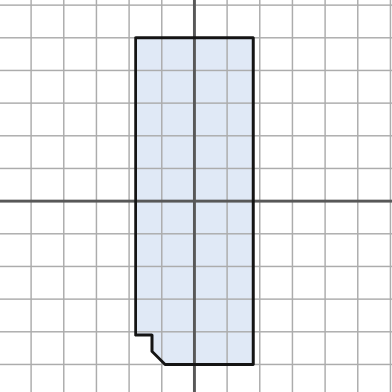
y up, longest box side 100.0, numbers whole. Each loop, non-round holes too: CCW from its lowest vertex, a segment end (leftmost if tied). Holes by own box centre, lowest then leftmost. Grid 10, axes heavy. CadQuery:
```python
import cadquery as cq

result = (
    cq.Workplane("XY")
    .moveTo(-9.0, -50.0)
    .lineTo(18.0, -50.0)
    .lineTo(18.0, 50.0)
    .lineTo(-18.0, 50.0)
    .lineTo(-18.0, -41.0)
    .lineTo(-13.0, -41.0)
    .lineTo(-13.0, -46.0)
    .close()
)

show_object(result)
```